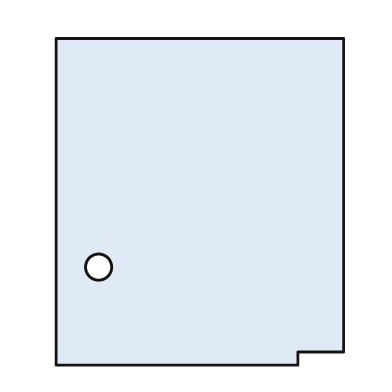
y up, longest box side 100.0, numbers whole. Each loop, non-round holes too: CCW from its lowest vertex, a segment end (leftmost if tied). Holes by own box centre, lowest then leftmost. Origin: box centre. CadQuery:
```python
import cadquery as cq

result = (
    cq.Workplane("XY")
    .moveTo(-44.0, -50.0)
    .lineTo(30.0, -50.0)
    .lineTo(30.0, -46.0)
    .lineTo(44.0, -46.0)
    .lineTo(44.0, 50.0)
    .lineTo(-44.0, 50.0)
    .close()
    .moveTo(-31.0, -20.0)
    .circle(4.0)
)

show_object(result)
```